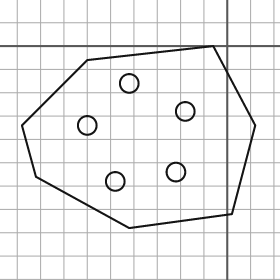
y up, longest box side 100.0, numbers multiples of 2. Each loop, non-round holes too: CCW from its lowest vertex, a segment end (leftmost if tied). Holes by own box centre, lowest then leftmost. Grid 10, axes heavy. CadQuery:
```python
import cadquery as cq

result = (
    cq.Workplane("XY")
    .moveTo(-42.0, -78.0)
    .lineTo(2.0, -72.0)
    .lineTo(12.0, -34.0)
    .lineTo(-6.0, 0.0)
    .lineTo(-60.0, -6.0)
    .lineTo(-88.0, -34.0)
    .lineTo(-82.0, -56.0)
    .close()
    .moveTo(-48.0, -58.0)
    .circle(4.0)
    .moveTo(-22.0, -54.0)
    .circle(4.0)
    .moveTo(-60.0, -34.0)
    .circle(4.0)
    .moveTo(-18.0, -28.0)
    .circle(4.0)
    .moveTo(-42.0, -16.0)
    .circle(4.0)
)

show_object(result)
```